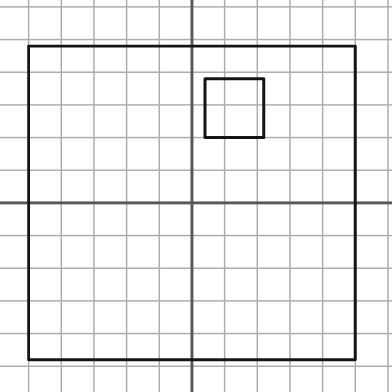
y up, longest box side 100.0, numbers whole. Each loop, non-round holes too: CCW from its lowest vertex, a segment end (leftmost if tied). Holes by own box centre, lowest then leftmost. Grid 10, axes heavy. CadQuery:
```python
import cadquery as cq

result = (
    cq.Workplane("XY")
    .moveTo(-50.0, -48.0)
    .lineTo(50.0, -48.0)
    .lineTo(50.0, 48.0)
    .lineTo(-50.0, 48.0)
    .close()
    .moveTo(4.0, 20.0)
    .lineTo(22.0, 20.0)
    .lineTo(22.0, 38.0)
    .lineTo(4.0, 38.0)
    .close()
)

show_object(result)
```